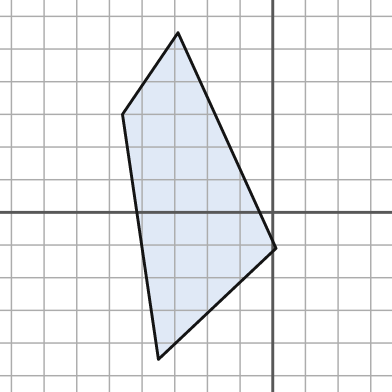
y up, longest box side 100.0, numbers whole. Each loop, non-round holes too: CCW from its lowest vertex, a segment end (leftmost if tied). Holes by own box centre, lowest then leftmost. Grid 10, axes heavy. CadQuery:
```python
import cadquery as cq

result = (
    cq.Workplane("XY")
    .moveTo(-35.0, -45.0)
    .lineTo(1.0, -11.0)
    .lineTo(-29.0, 55.0)
    .lineTo(-46.0, 30.0)
    .close()
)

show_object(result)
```